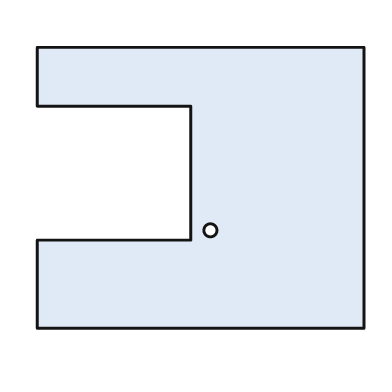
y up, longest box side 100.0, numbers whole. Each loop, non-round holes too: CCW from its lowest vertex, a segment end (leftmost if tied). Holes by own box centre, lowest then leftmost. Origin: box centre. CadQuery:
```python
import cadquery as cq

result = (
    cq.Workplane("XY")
    .moveTo(-50.0, -43.0)
    .lineTo(50.0, -43.0)
    .lineTo(50.0, 43.0)
    .lineTo(-50.0, 43.0)
    .lineTo(-50.0, 25.0)
    .lineTo(-3.0, 25.0)
    .lineTo(-3.0, -16.0)
    .lineTo(-50.0, -16.0)
    .close()
    .moveTo(3.0, -13.0)
    .circle(2.0)
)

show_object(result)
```